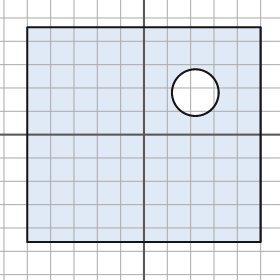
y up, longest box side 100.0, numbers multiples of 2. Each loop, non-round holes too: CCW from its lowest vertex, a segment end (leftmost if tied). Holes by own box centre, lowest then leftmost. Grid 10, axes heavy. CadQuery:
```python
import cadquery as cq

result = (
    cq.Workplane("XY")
    .moveTo(-50.0, -46.0)
    .lineTo(50.0, -46.0)
    .lineTo(50.0, 46.0)
    .lineTo(-50.0, 46.0)
    .close()
    .moveTo(22.0, 18.0)
    .circle(10.0)
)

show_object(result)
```